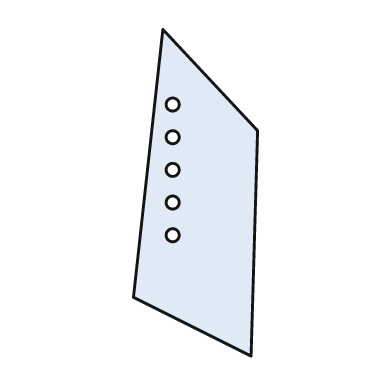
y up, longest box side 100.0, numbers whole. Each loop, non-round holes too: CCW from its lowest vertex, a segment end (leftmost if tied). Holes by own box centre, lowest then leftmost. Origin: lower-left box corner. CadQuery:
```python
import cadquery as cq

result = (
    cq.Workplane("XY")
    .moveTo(36.0, 0.0)
    .lineTo(38.0, 69.0)
    .lineTo(9.0, 100.0)
    .lineTo(0.0, 18.0)
    .close()
    .moveTo(12.0, 37.0)
    .circle(2.0)
    .moveTo(12.0, 47.0)
    .circle(2.0)
    .moveTo(12.0, 57.0)
    .circle(2.0)
    .moveTo(12.0, 67.0)
    .circle(2.0)
    .moveTo(12.0, 77.0)
    .circle(2.0)
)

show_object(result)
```